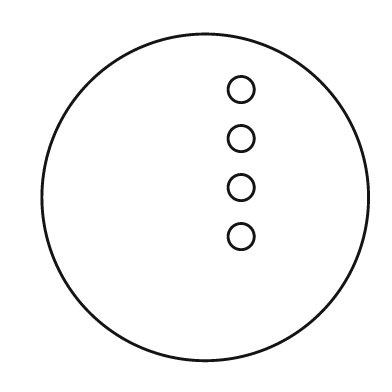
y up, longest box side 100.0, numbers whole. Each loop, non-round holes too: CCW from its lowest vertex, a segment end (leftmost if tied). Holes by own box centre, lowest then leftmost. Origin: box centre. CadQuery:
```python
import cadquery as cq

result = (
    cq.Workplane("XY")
    .moveTo(0.0, 0.0)
    .circle(50.0)
    .moveTo(11.0, -12.0)
    .circle(4.0)
    .moveTo(11.0, 3.0)
    .circle(4.0)
    .moveTo(11.0, 18.0)
    .circle(4.0)
    .moveTo(11.0, 33.0)
    .circle(4.0)
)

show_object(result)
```